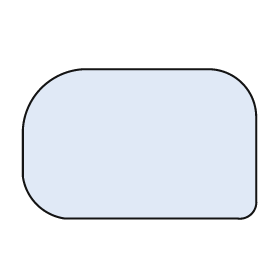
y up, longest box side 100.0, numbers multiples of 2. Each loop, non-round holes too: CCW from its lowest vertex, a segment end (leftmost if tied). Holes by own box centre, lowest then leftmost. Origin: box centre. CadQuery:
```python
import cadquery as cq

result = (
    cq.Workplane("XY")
    .moveTo(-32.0, -32.0)
    .lineTo(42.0, -32.0)
    .threePointArc((48.0, -30.0), (50.0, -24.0))
    .lineTo(50.0, 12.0)
    .threePointArc((44.0, 26.0), (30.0, 32.0))
    .lineTo(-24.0, 32.0)
    .threePointArc((-42.0, 24.0), (-50.0, 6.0))
    .lineTo(-50.0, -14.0)
    .threePointArc((-44.0, -26.0), (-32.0, -32.0))
    .close()
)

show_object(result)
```